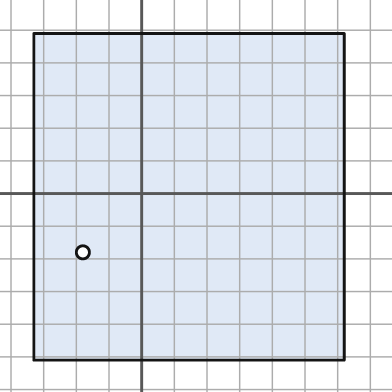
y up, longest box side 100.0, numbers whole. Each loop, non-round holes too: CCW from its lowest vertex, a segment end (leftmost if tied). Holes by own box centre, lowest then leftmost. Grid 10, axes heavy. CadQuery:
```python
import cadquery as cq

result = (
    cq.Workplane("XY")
    .moveTo(-33.0, -51.0)
    .lineTo(62.0, -51.0)
    .lineTo(62.0, 49.0)
    .lineTo(-33.0, 49.0)
    .close()
    .moveTo(-18.0, -18.0)
    .circle(2.0)
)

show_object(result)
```